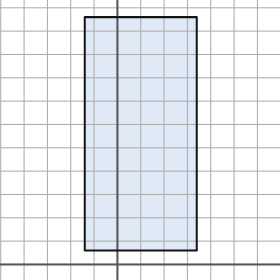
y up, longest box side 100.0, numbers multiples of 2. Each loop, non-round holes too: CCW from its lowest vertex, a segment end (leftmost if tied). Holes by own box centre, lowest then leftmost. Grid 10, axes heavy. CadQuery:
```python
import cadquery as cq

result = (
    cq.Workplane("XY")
    .moveTo(-14.0, 6.0)
    .lineTo(34.0, 6.0)
    .lineTo(34.0, 106.0)
    .lineTo(-14.0, 106.0)
    .close()
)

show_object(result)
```